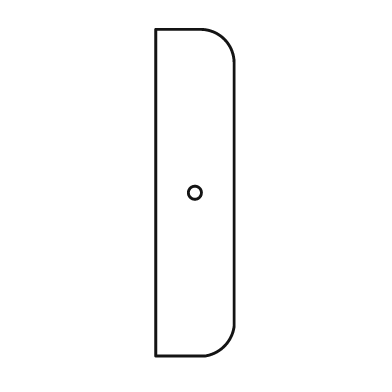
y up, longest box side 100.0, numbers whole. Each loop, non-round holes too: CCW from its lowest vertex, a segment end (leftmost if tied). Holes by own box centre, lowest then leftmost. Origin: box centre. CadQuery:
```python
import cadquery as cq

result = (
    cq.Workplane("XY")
    .moveTo(-12.0, -50.0)
    .lineTo(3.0, -50.0)
    .threePointArc((9.0, -47.0), (12.0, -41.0))
    .lineTo(12.0, 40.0)
    .threePointArc((9.0, 47.0), (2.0, 50.0))
    .lineTo(-12.0, 50.0)
    .close()
    .moveTo(0.0, 0.0)
    .circle(2.0)
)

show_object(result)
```